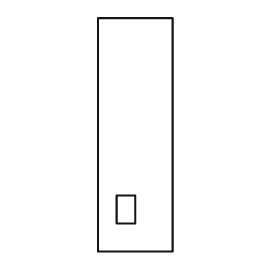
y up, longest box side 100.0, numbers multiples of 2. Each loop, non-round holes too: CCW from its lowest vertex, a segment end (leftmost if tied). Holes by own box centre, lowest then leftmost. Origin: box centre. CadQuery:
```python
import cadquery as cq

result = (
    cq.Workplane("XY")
    .moveTo(-16.0, -50.0)
    .lineTo(16.0, -50.0)
    .lineTo(16.0, 50.0)
    .lineTo(-16.0, 50.0)
    .close()
    .moveTo(-8.0, -38.0)
    .lineTo(0.0, -38.0)
    .lineTo(0.0, -26.0)
    .lineTo(-8.0, -26.0)
    .close()
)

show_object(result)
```